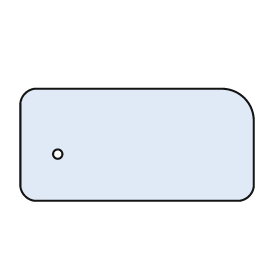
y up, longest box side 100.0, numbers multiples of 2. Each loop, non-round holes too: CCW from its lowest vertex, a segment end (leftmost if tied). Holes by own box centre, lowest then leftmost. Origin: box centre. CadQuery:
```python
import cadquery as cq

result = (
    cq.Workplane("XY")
    .moveTo(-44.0, -24.0)
    .lineTo(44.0, -24.0)
    .threePointArc((48.0, -22.0), (50.0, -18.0))
    .lineTo(50.0, 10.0)
    .threePointArc((46.0, 20.0), (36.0, 24.0))
    .lineTo(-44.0, 24.0)
    .threePointArc((-48.0, 22.0), (-50.0, 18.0))
    .lineTo(-50.0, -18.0)
    .threePointArc((-48.0, -22.0), (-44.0, -24.0))
    .close()
    .moveTo(-34.0, -4.0)
    .circle(2.0)
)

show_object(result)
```